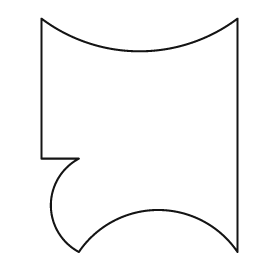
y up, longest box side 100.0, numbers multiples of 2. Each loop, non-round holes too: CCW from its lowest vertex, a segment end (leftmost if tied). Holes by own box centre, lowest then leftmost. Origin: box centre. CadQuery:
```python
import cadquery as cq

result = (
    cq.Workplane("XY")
    .moveTo(-26.0, -50.0)
    .threePointArc((8.0, -32.0), (42.0, -50.0))
    .lineTo(42.0, 50.0)
    .threePointArc((0.0, 36.0), (-42.0, 50.0))
    .lineTo(-42.0, -10.0)
    .lineTo(-26.0, -10.0)
    .threePointArc((-38.0, -30.0), (-26.0, -50.0))
    .close()
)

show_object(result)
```